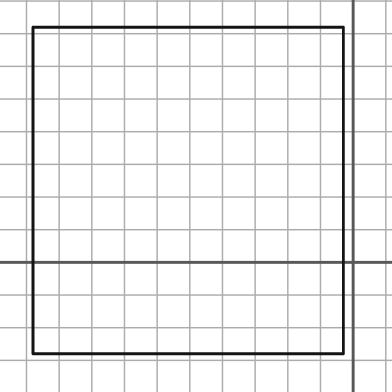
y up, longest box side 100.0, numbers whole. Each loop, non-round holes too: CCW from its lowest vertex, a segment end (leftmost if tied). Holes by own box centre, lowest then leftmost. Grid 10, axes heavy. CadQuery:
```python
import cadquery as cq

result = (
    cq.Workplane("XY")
    .moveTo(-98.0, -28.0)
    .lineTo(-3.0, -28.0)
    .lineTo(-3.0, 72.0)
    .lineTo(-98.0, 72.0)
    .close()
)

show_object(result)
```